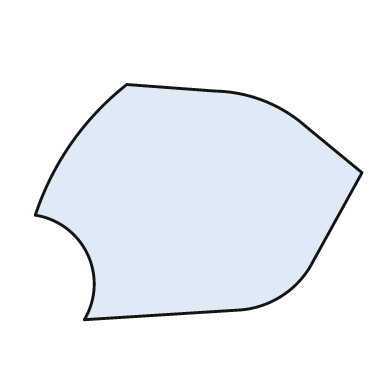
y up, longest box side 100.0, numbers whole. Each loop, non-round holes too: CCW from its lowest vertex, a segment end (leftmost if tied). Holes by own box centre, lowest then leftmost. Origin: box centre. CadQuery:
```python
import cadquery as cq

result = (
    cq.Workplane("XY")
    .moveTo(-35.0, -36.0)
    .lineTo(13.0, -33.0)
    .threePointArc((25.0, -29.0), (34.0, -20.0))
    .lineTo(50.0, 9.0)
    .lineTo(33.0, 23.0)
    .threePointArc((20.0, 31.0), (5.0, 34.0))
    .lineTo(-22.0, 36.0)
    .threePointArc((-39.0, 18.0), (-50.0, -4.0))
    .threePointArc((-34.0, -16.0), (-35.0, -36.0))
    .close()
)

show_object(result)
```